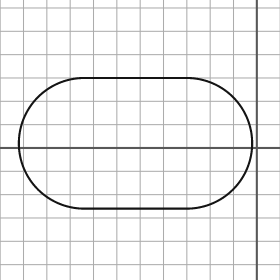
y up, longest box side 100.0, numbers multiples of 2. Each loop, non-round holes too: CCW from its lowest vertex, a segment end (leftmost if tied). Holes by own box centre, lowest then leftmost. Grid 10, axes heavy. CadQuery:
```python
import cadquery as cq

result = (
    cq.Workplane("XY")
    .moveTo(-74.0, -26.0)
    .lineTo(-30.0, -26.0)
    .threePointArc((-2.0, 2.0), (-30.0, 30.0))
    .lineTo(-74.0, 30.0)
    .threePointArc((-102.0, 2.0), (-74.0, -26.0))
    .close()
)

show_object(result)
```